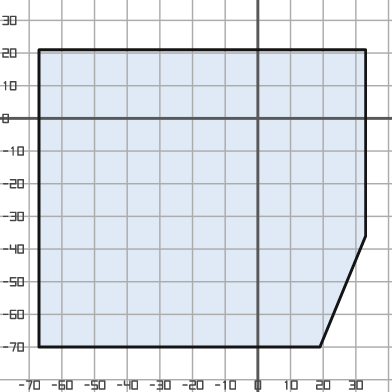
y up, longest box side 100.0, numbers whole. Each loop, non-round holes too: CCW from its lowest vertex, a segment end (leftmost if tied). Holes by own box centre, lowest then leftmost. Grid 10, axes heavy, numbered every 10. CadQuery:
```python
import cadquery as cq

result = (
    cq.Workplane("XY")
    .moveTo(-67.0, -70.0)
    .lineTo(19.0, -70.0)
    .lineTo(33.0, -36.0)
    .lineTo(33.0, 21.0)
    .lineTo(-67.0, 21.0)
    .close()
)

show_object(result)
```